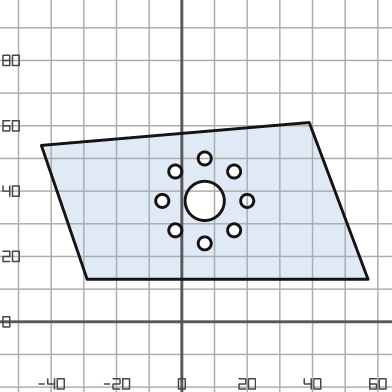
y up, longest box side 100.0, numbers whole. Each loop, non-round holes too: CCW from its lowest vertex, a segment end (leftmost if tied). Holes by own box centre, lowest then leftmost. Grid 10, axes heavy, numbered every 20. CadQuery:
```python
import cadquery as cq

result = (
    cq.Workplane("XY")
    .moveTo(-29.0, 13.0)
    .lineTo(57.0, 13.0)
    .lineTo(39.0, 61.0)
    .lineTo(-43.0, 54.0)
    .close()
    .moveTo(7.0, 24.0)
    .circle(2.0)
    .moveTo(-2.0, 28.0)
    .circle(2.0)
    .moveTo(16.0, 28.0)
    .circle(2.0)
    .moveTo(-6.0, 37.0)
    .circle(2.0)
    .moveTo(7.0, 37.0)
    .circle(6.0)
    .moveTo(20.0, 37.0)
    .circle(2.0)
    .moveTo(-2.0, 46.0)
    .circle(2.0)
    .moveTo(16.0, 46.0)
    .circle(2.0)
    .moveTo(7.0, 50.0)
    .circle(2.0)
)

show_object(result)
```